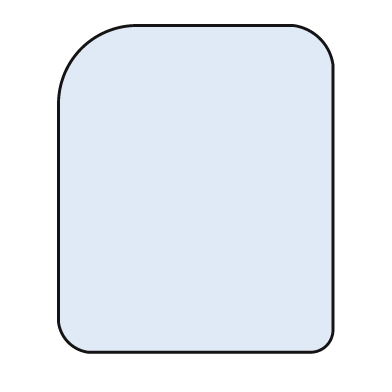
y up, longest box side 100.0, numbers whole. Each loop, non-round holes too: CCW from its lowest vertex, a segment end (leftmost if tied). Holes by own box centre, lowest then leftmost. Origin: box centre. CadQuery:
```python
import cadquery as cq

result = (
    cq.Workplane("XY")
    .moveTo(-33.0, -50.0)
    .lineTo(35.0, -50.0)
    .threePointArc((40.0, -48.0), (42.0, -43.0))
    .lineTo(42.0, 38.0)
    .threePointArc((38.0, 46.0), (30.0, 50.0))
    .lineTo(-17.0, 50.0)
    .threePointArc((-35.0, 43.0), (-42.0, 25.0))
    .lineTo(-42.0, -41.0)
    .threePointArc((-39.0, -47.0), (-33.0, -50.0))
    .close()
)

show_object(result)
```